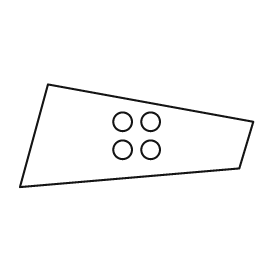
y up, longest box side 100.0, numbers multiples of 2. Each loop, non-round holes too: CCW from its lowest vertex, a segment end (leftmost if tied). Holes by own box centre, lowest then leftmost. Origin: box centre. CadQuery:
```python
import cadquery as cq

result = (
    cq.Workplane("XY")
    .moveTo(-50.0, -22.0)
    .lineTo(44.0, -14.0)
    .lineTo(50.0, 6.0)
    .lineTo(-38.0, 22.0)
    .close()
    .moveTo(-6.0, -6.0)
    .circle(4.0)
    .moveTo(6.0, -6.0)
    .circle(4.0)
    .moveTo(-6.0, 6.0)
    .circle(4.0)
    .moveTo(6.0, 6.0)
    .circle(4.0)
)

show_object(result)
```